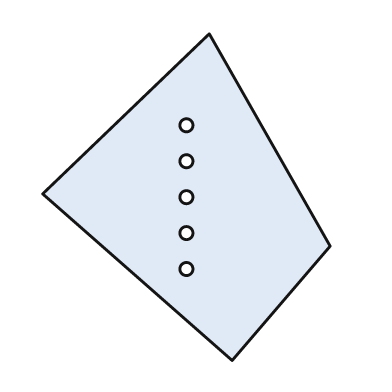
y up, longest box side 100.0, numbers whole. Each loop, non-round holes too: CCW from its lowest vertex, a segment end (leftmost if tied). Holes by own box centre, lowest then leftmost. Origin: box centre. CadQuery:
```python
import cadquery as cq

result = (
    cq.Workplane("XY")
    .moveTo(14.0, -50.0)
    .lineTo(44.0, -15.0)
    .lineTo(7.0, 50.0)
    .lineTo(-44.0, 1.0)
    .close()
    .moveTo(0.0, -22.0)
    .circle(2.0)
    .moveTo(0.0, -11.0)
    .circle(2.0)
    .moveTo(0.0, 0.0)
    .circle(2.0)
    .moveTo(0.0, 11.0)
    .circle(2.0)
    .moveTo(0.0, 22.0)
    .circle(2.0)
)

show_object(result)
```